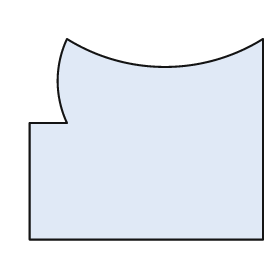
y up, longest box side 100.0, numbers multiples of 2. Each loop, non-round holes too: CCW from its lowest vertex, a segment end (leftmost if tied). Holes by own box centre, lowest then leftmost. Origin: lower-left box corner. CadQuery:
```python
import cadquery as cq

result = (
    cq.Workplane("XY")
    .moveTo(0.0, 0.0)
    .lineTo(100.0, 0.0)
    .lineTo(100.0, 86.0)
    .threePointArc((58.0, 74.0), (16.0, 86.0))
    .threePointArc((12.0, 68.0), (16.0, 50.0))
    .lineTo(0.0, 50.0)
    .close()
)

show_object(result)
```